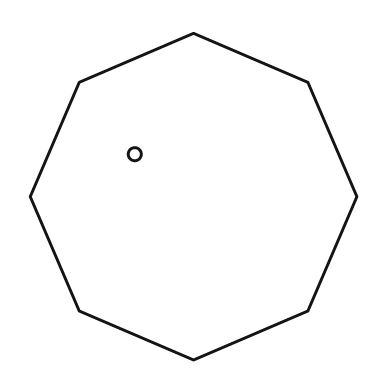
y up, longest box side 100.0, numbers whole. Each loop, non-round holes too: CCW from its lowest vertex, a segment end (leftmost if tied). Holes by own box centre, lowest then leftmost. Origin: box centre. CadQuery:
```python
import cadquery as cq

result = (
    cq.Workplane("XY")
    .moveTo(0.0, -50.0)
    .lineTo(35.0, -35.0)
    .lineTo(50.0, 0.0)
    .lineTo(35.0, 35.0)
    .lineTo(0.0, 50.0)
    .lineTo(-35.0, 35.0)
    .lineTo(-50.0, 0.0)
    .lineTo(-35.0, -35.0)
    .close()
    .moveTo(-18.0, 13.0)
    .circle(2.0)
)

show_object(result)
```